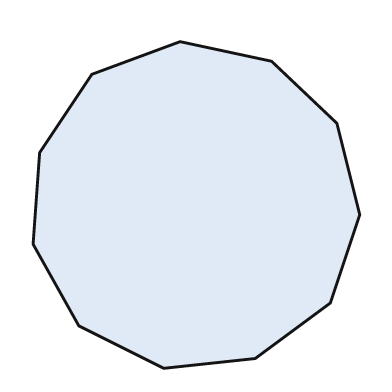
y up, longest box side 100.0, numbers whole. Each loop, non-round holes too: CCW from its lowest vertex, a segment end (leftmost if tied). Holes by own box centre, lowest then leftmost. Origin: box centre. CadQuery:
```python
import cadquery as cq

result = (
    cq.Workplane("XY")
    .moveTo(-10.0, -50.0)
    .lineTo(18.0, -47.0)
    .lineTo(41.0, -30.0)
    .lineTo(50.0, -3.0)
    .lineTo(43.0, 25.0)
    .lineTo(23.0, 44.0)
    .lineTo(-5.0, 50.0)
    .lineTo(-32.0, 40.0)
    .lineTo(-48.0, 16.0)
    .lineTo(-50.0, -12.0)
    .lineTo(-36.0, -37.0)
    .close()
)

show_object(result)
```